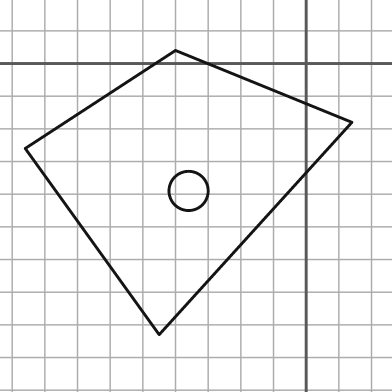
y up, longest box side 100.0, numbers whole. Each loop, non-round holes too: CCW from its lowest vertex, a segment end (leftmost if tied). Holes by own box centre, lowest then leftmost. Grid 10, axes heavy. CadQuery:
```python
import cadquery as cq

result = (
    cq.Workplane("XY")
    .moveTo(-45.0, -83.0)
    .lineTo(14.0, -18.0)
    .lineTo(-40.0, 4.0)
    .lineTo(-86.0, -26.0)
    .close()
    .moveTo(-36.0, -39.0)
    .circle(6.0)
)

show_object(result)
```